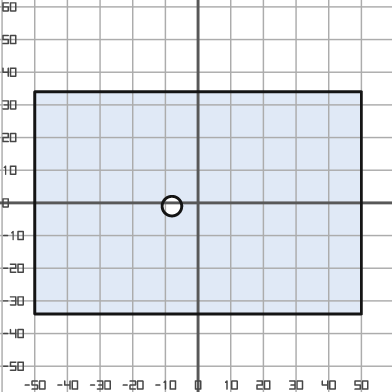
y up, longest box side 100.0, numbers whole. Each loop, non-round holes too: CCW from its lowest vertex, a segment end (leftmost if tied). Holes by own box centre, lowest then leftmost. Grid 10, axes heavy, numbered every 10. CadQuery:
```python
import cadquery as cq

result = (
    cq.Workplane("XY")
    .moveTo(-50.0, -34.0)
    .lineTo(50.0, -34.0)
    .lineTo(50.0, 34.0)
    .lineTo(-50.0, 34.0)
    .close()
    .moveTo(-8.0, -1.0)
    .circle(3.0)
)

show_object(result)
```